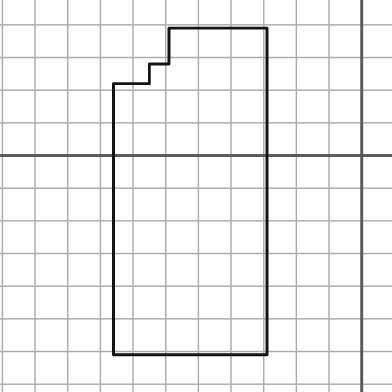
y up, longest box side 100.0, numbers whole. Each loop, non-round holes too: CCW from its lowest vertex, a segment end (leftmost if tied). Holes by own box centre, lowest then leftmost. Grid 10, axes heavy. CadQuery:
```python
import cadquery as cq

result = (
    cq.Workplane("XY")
    .moveTo(-76.0, -61.0)
    .lineTo(-29.0, -61.0)
    .lineTo(-29.0, 39.0)
    .lineTo(-59.0, 39.0)
    .lineTo(-59.0, 28.0)
    .lineTo(-65.0, 28.0)
    .lineTo(-65.0, 22.0)
    .lineTo(-76.0, 22.0)
    .close()
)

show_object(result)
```